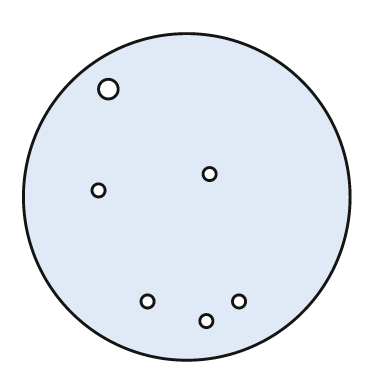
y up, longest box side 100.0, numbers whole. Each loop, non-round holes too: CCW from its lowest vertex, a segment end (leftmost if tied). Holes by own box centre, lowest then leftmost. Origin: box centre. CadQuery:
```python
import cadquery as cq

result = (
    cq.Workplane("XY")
    .moveTo(0.0, 0.0)
    .circle(50.0)
    .moveTo(6.0, -38.0)
    .circle(2.0)
    .moveTo(-12.0, -32.0)
    .circle(2.0)
    .moveTo(16.0, -32.0)
    .circle(2.0)
    .moveTo(-27.0, 2.0)
    .circle(2.0)
    .moveTo(7.0, 7.0)
    .circle(2.0)
    .moveTo(-24.0, 33.0)
    .circle(3.0)
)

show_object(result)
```